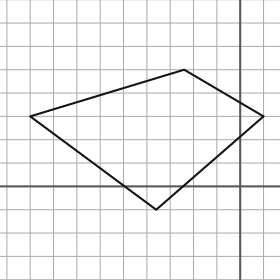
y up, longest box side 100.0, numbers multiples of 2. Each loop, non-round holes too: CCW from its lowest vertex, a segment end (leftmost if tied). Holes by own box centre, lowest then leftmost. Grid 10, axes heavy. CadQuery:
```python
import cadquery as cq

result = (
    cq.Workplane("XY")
    .moveTo(-36.0, -10.0)
    .lineTo(10.0, 30.0)
    .lineTo(-24.0, 50.0)
    .lineTo(-90.0, 30.0)
    .close()
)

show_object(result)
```